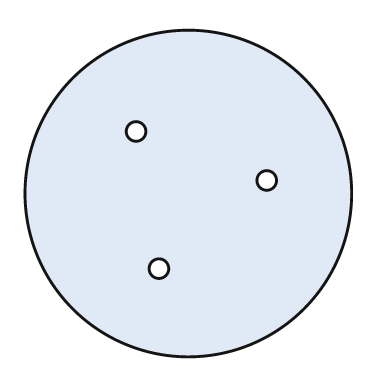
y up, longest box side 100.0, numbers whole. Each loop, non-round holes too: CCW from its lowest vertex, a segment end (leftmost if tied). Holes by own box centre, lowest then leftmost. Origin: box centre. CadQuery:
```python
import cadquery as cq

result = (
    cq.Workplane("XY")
    .moveTo(0.0, 0.0)
    .circle(50.0)
    .moveTo(-9.0, -23.0)
    .circle(3.0)
    .moveTo(24.0, 4.0)
    .circle(3.0)
    .moveTo(-16.0, 19.0)
    .circle(3.0)
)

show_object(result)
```